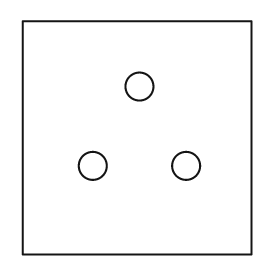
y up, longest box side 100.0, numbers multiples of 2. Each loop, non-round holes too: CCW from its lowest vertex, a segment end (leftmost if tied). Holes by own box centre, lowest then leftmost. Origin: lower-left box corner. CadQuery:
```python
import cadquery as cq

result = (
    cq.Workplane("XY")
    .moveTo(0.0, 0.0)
    .lineTo(98.0, 0.0)
    .lineTo(98.0, 100.0)
    .lineTo(0.0, 100.0)
    .close()
    .moveTo(30.0, 38.0)
    .circle(6.0)
    .moveTo(70.0, 38.0)
    .circle(6.0)
    .moveTo(50.0, 72.0)
    .circle(6.0)
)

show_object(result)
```